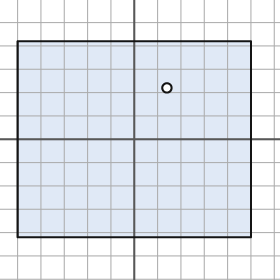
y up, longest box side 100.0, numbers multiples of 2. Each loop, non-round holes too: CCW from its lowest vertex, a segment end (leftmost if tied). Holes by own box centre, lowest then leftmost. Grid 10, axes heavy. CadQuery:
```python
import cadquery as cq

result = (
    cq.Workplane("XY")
    .moveTo(-50.0, -42.0)
    .lineTo(50.0, -42.0)
    .lineTo(50.0, 42.0)
    .lineTo(-50.0, 42.0)
    .close()
    .moveTo(14.0, 22.0)
    .circle(2.0)
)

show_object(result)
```